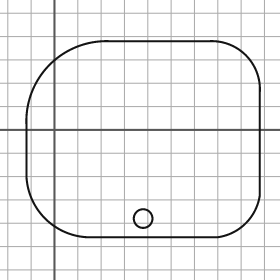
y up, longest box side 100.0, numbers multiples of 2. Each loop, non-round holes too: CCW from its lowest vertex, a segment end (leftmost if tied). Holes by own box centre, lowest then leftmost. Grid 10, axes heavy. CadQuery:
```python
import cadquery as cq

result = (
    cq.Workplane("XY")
    .moveTo(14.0, -46.0)
    .lineTo(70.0, -46.0)
    .threePointArc((82.0, -40.0), (88.0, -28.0))
    .lineTo(88.0, 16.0)
    .threePointArc((82.0, 32.0), (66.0, 38.0))
    .lineTo(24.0, 38.0)
    .threePointArc((-2.0, 28.0), (-12.0, 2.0))
    .lineTo(-12.0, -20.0)
    .threePointArc((-4.0, -38.0), (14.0, -46.0))
    .close()
    .moveTo(38.0, -38.0)
    .circle(4.0)
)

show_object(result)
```